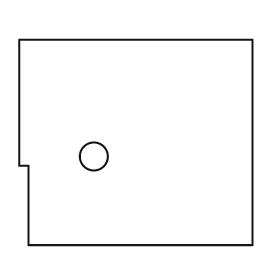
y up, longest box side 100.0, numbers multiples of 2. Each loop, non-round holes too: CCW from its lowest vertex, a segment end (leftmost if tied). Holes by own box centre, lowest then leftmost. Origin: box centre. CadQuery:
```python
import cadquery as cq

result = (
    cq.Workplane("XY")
    .moveTo(-46.0, -44.0)
    .lineTo(50.0, -44.0)
    .lineTo(50.0, 44.0)
    .lineTo(-50.0, 44.0)
    .lineTo(-50.0, -10.0)
    .lineTo(-46.0, -10.0)
    .close()
    .moveTo(-18.0, -6.0)
    .circle(6.0)
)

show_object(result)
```